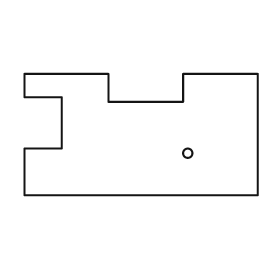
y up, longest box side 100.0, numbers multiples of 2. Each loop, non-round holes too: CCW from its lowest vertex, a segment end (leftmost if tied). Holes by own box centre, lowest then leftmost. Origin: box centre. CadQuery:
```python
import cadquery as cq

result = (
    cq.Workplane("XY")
    .moveTo(-50.0, -26.0)
    .lineTo(50.0, -26.0)
    .lineTo(50.0, 26.0)
    .lineTo(18.0, 26.0)
    .lineTo(18.0, 14.0)
    .lineTo(-14.0, 14.0)
    .lineTo(-14.0, 26.0)
    .lineTo(-50.0, 26.0)
    .lineTo(-50.0, 16.0)
    .lineTo(-34.0, 16.0)
    .lineTo(-34.0, -6.0)
    .lineTo(-50.0, -6.0)
    .close()
    .moveTo(20.0, -8.0)
    .circle(2.0)
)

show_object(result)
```